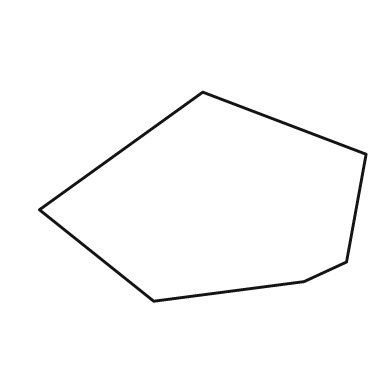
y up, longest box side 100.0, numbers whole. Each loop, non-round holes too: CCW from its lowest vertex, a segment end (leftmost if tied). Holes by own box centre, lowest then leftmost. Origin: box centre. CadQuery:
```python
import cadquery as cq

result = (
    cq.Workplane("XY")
    .moveTo(-15.0, -32.0)
    .lineTo(31.0, -26.0)
    .lineTo(44.0, -20.0)
    .lineTo(50.0, 13.0)
    .lineTo(0.0, 32.0)
    .lineTo(-50.0, -4.0)
    .close()
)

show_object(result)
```